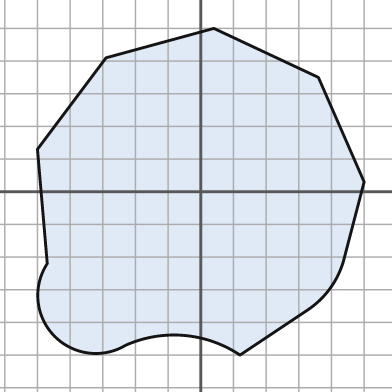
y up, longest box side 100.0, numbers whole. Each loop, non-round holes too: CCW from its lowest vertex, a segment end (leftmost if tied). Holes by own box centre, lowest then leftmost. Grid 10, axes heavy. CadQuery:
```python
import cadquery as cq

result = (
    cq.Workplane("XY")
    .moveTo(12.0, -50.0)
    .lineTo(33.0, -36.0)
    .threePointArc((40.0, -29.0), (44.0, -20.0))
    .lineTo(50.0, 3.0)
    .lineTo(36.0, 35.0)
    .lineTo(4.0, 50.0)
    .lineTo(-29.0, 41.0)
    .lineTo(-50.0, 13.0)
    .lineTo(-47.0, -22.0)
    .threePointArc((-45.0, -44.0), (-23.0, -47.0))
    .threePointArc((-5.0, -44.0), (12.0, -50.0))
    .close()
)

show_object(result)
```